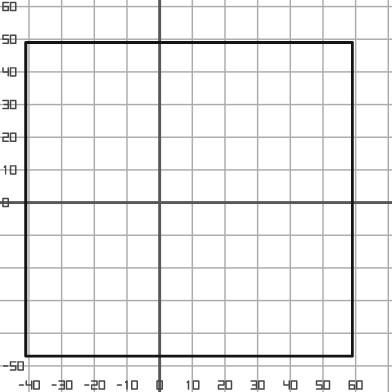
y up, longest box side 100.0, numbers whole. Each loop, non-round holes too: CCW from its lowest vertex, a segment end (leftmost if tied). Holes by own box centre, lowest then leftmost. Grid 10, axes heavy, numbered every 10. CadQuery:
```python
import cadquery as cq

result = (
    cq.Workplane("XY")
    .moveTo(-41.0, -47.0)
    .lineTo(59.0, -47.0)
    .lineTo(59.0, 49.0)
    .lineTo(-41.0, 49.0)
    .close()
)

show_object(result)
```